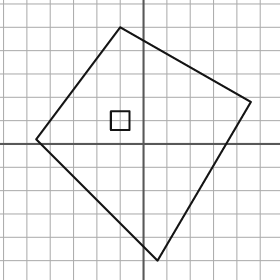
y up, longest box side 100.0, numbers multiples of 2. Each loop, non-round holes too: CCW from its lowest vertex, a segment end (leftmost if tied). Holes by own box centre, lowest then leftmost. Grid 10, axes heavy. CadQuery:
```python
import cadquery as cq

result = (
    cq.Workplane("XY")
    .moveTo(6.0, -50.0)
    .lineTo(46.0, 18.0)
    .lineTo(-10.0, 50.0)
    .lineTo(-46.0, 2.0)
    .close()
    .moveTo(-14.0, 6.0)
    .lineTo(-6.0, 6.0)
    .lineTo(-6.0, 14.0)
    .lineTo(-14.0, 14.0)
    .close()
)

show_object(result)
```